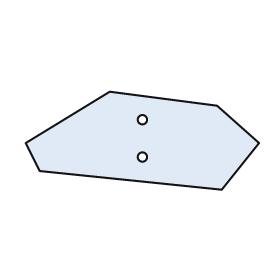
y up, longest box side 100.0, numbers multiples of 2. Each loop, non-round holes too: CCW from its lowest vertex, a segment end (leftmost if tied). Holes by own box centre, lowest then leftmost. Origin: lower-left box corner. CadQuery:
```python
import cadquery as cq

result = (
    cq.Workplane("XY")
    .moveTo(84.0, 0.0)
    .lineTo(100.0, 20.0)
    .lineTo(82.0, 36.0)
    .lineTo(36.0, 42.0)
    .lineTo(0.0, 20.0)
    .lineTo(6.0, 8.0)
    .close()
    .moveTo(50.0, 14.0)
    .circle(2.0)
    .moveTo(50.0, 30.0)
    .circle(2.0)
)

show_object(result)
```